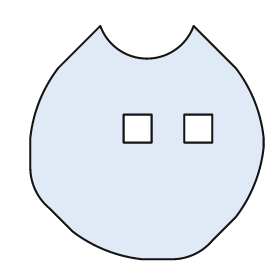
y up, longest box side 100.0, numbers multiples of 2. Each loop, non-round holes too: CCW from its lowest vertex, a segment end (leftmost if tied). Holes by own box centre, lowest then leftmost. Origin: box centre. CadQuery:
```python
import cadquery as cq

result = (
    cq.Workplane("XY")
    .moveTo(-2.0, -50.0)
    .lineTo(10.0, -50.0)
    .threePointArc((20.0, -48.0), (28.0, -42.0))
    .lineTo(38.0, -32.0)
    .threePointArc((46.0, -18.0), (50.0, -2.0))
    .lineTo(50.0, 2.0)
    .threePointArc((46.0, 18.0), (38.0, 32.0))
    .lineTo(20.0, 50.0)
    .threePointArc((0.0, 36.0), (-20.0, 50.0))
    .lineTo(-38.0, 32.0)
    .threePointArc((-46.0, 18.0), (-50.0, 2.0))
    .lineTo(-50.0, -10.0)
    .threePointArc((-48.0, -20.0), (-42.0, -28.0))
    .lineTo(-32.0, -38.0)
    .threePointArc((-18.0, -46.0), (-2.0, -50.0))
    .close()
    .moveTo(-10.0, 0.0)
    .lineTo(2.0, 0.0)
    .lineTo(2.0, 12.0)
    .lineTo(-10.0, 12.0)
    .close()
    .moveTo(16.0, 0.0)
    .lineTo(28.0, 0.0)
    .lineTo(28.0, 12.0)
    .lineTo(16.0, 12.0)
    .close()
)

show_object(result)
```